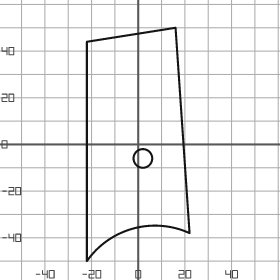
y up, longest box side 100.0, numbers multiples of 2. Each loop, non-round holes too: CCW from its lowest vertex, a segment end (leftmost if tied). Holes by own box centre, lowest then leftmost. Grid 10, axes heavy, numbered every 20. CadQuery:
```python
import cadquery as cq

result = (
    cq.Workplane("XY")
    .moveTo(-22.0, -50.0)
    .threePointArc((-2.0, -36.0), (22.0, -38.0))
    .lineTo(16.0, 50.0)
    .lineTo(-22.0, 44.0)
    .close()
    .moveTo(2.0, -6.0)
    .circle(4.0)
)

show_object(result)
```